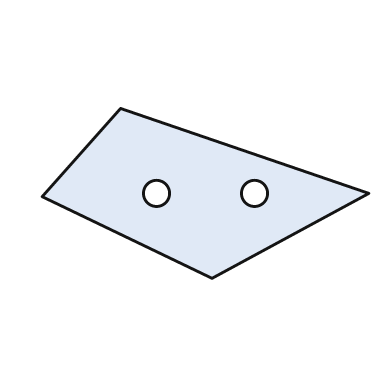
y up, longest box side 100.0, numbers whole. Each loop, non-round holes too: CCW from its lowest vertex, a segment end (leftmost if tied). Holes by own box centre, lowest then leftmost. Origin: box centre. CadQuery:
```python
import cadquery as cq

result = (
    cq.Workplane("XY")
    .moveTo(2.0, -26.0)
    .lineTo(50.0, 0.0)
    .lineTo(-26.0, 26.0)
    .lineTo(-50.0, -1.0)
    .close()
    .moveTo(-15.0, 0.0)
    .circle(4.0)
    .moveTo(15.0, 0.0)
    .circle(4.0)
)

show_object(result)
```